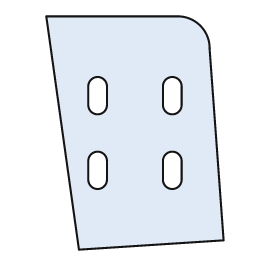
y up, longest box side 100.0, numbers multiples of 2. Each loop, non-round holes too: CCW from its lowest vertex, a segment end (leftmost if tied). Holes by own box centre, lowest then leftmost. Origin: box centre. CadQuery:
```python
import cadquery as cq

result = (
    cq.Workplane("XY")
    .moveTo(-24.0, -50.0)
    .lineTo(38.0, -46.0)
    .lineTo(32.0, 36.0)
    .threePointArc((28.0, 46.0), (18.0, 50.0))
    .lineTo(-38.0, 50.0)
    .close()
    .moveTo(-20.0, -20.0)
    .threePointArc((-16.0, -24.0), (-12.0, -20.0))
    .lineTo(-12.0, -12.0)
    .threePointArc((-16.0, -8.0), (-20.0, -12.0))
    .close()
    .moveTo(12.0, -20.0)
    .threePointArc((16.0, -24.0), (20.0, -20.0))
    .lineTo(20.0, -12.0)
    .threePointArc((16.0, -8.0), (12.0, -12.0))
    .close()
    .moveTo(-20.0, 12.0)
    .threePointArc((-16.0, 8.0), (-12.0, 12.0))
    .lineTo(-12.0, 20.0)
    .threePointArc((-16.0, 24.0), (-20.0, 20.0))
    .close()
    .moveTo(12.0, 12.0)
    .threePointArc((16.0, 8.0), (20.0, 12.0))
    .lineTo(20.0, 20.0)
    .threePointArc((16.0, 24.0), (12.0, 20.0))
    .close()
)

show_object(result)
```